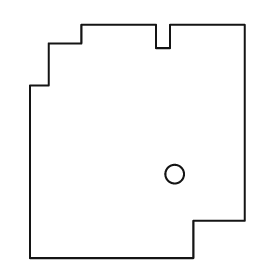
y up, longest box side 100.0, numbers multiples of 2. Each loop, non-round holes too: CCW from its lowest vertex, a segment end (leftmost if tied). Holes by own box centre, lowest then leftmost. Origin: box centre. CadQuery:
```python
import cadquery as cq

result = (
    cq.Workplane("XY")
    .moveTo(-46.0, -50.0)
    .lineTo(24.0, -50.0)
    .lineTo(24.0, -34.0)
    .lineTo(46.0, -34.0)
    .lineTo(46.0, 50.0)
    .lineTo(14.0, 50.0)
    .lineTo(14.0, 40.0)
    .lineTo(8.0, 40.0)
    .lineTo(8.0, 50.0)
    .lineTo(-24.0, 50.0)
    .lineTo(-24.0, 42.0)
    .lineTo(-38.0, 42.0)
    .lineTo(-38.0, 24.0)
    .lineTo(-46.0, 24.0)
    .close()
    .moveTo(16.0, -14.0)
    .circle(4.0)
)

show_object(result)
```